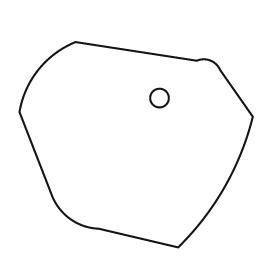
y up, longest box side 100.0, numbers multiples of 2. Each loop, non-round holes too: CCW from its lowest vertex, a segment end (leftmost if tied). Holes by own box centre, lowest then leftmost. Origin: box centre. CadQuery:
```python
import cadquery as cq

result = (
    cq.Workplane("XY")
    .moveTo(18.0, -44.0)
    .threePointArc((38.0, -18.0), (50.0, 12.0))
    .lineTo(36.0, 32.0)
    .threePointArc((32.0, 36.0), (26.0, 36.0))
    .lineTo(-26.0, 44.0)
    .threePointArc((-42.0, 32.0), (-50.0, 14.0))
    .lineTo(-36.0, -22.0)
    .threePointArc((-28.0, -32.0), (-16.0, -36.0))
    .close()
    .moveTo(10.0, 20.0)
    .circle(4.0)
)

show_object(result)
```